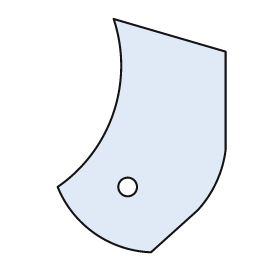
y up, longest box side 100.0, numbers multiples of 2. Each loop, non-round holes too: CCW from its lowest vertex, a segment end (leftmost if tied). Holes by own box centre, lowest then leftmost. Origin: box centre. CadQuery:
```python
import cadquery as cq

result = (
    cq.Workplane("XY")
    .moveTo(4.0, -50.0)
    .lineTo(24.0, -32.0)
    .threePointArc((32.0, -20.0), (36.0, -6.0))
    .lineTo(36.0, 36.0)
    .lineTo(-12.0, 50.0)
    .threePointArc((-12.0, 10.0), (-36.0, -22.0))
    .threePointArc((-20.0, -42.0), (4.0, -50.0))
    .close()
    .moveTo(-6.0, -22.0)
    .circle(4.0)
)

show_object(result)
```